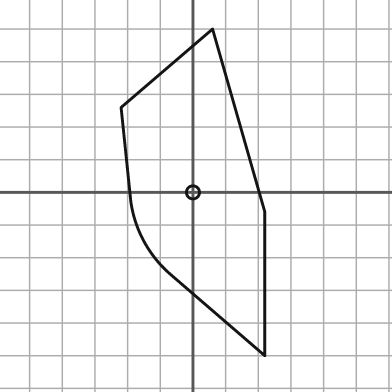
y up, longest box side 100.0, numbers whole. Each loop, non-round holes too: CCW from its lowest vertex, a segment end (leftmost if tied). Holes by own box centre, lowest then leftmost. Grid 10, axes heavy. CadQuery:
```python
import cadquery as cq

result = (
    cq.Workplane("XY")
    .moveTo(22.0, -50.0)
    .lineTo(22.0, -6.0)
    .lineTo(6.0, 50.0)
    .lineTo(-22.0, 26.0)
    .lineTo(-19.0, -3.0)
    .threePointArc((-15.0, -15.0), (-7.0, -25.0))
    .close()
    .moveTo(0.0, 0.0)
    .circle(2.0)
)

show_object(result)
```